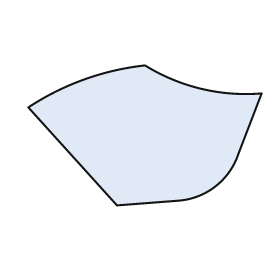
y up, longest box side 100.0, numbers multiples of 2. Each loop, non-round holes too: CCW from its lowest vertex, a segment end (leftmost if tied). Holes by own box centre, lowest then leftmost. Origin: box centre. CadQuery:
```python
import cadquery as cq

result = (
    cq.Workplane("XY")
    .moveTo(-12.0, -30.0)
    .lineTo(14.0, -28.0)
    .threePointArc((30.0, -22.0), (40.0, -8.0))
    .lineTo(50.0, 18.0)
    .threePointArc((24.0, 20.0), (0.0, 30.0))
    .threePointArc((-26.0, 24.0), (-50.0, 12.0))
    .close()
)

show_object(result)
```